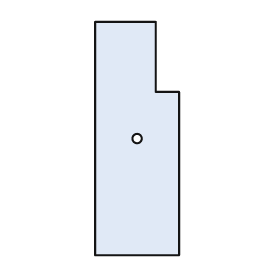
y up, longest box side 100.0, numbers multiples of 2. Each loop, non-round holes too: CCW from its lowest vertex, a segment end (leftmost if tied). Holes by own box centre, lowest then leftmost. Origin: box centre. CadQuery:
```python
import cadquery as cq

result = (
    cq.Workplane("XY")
    .moveTo(-18.0, -50.0)
    .lineTo(18.0, -50.0)
    .lineTo(18.0, 20.0)
    .lineTo(8.0, 20.0)
    .lineTo(8.0, 50.0)
    .lineTo(-18.0, 50.0)
    .close()
    .moveTo(0.0, 0.0)
    .circle(2.0)
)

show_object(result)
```